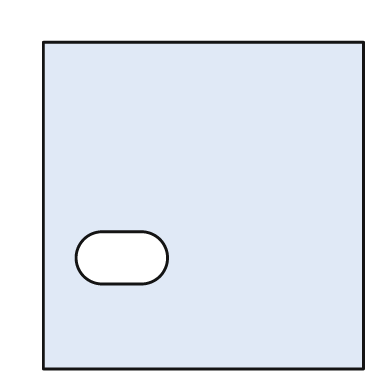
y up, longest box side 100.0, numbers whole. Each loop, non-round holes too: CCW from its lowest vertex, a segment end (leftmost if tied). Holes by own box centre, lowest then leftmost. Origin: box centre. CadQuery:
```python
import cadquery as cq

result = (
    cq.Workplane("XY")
    .moveTo(-49.0, -50.0)
    .lineTo(49.0, -50.0)
    .lineTo(49.0, 50.0)
    .lineTo(-49.0, 50.0)
    .close()
    .moveTo(-31.0, -24.0)
    .lineTo(-19.0, -24.0)
    .threePointArc((-11.0, -16.0), (-19.0, -8.0))
    .lineTo(-31.0, -8.0)
    .threePointArc((-39.0, -16.0), (-31.0, -24.0))
    .close()
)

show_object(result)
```